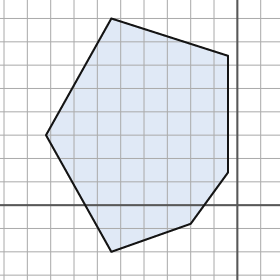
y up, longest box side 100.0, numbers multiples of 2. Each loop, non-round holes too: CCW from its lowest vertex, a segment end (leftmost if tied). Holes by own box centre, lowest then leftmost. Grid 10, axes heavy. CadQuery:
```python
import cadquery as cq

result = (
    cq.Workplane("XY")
    .moveTo(-54.0, -20.0)
    .lineTo(-20.0, -8.0)
    .lineTo(-4.0, 14.0)
    .lineTo(-4.0, 64.0)
    .lineTo(-54.0, 80.0)
    .lineTo(-82.0, 30.0)
    .close()
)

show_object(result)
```